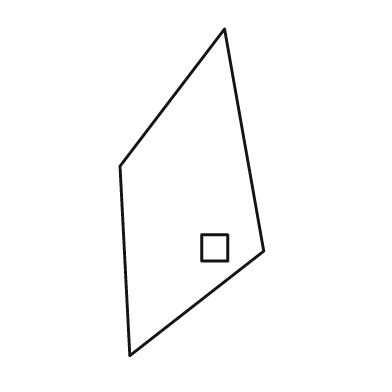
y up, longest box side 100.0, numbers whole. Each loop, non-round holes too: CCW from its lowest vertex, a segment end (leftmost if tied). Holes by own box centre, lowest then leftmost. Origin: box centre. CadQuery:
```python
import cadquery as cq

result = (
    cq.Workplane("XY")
    .moveTo(-19.0, -50.0)
    .lineTo(22.0, -18.0)
    .lineTo(10.0, 50.0)
    .lineTo(-22.0, 8.0)
    .close()
    .moveTo(3.0, -21.0)
    .lineTo(11.0, -21.0)
    .lineTo(11.0, -13.0)
    .lineTo(3.0, -13.0)
    .close()
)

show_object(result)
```